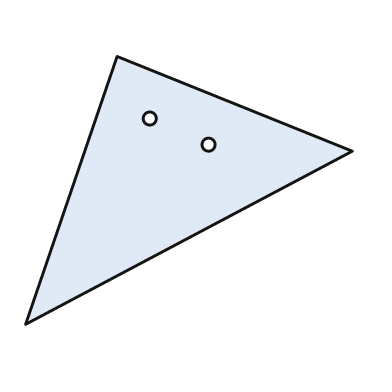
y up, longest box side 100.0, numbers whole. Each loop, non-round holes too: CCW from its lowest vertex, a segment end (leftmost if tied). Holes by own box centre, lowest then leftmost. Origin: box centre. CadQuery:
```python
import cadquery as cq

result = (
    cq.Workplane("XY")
    .moveTo(-50.0, -41.0)
    .lineTo(50.0, 12.0)
    .lineTo(-22.0, 41.0)
    .close()
    .moveTo(6.0, 14.0)
    .circle(2.0)
    .moveTo(-12.0, 22.0)
    .circle(2.0)
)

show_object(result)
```